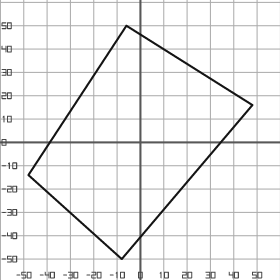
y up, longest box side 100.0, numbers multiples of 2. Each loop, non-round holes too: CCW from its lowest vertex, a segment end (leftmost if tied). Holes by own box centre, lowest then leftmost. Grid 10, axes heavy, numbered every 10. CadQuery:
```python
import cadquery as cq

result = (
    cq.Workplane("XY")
    .moveTo(-8.0, -50.0)
    .lineTo(48.0, 16.0)
    .lineTo(-6.0, 50.0)
    .lineTo(-48.0, -14.0)
    .close()
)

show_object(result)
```